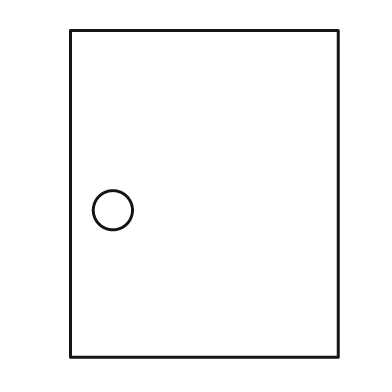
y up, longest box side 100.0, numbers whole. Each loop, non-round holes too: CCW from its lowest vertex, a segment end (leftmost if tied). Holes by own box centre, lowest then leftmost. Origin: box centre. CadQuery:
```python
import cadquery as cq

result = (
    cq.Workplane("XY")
    .moveTo(-41.0, -50.0)
    .lineTo(41.0, -50.0)
    .lineTo(41.0, 50.0)
    .lineTo(-41.0, 50.0)
    .close()
    .moveTo(-28.0, -5.0)
    .circle(6.0)
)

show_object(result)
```